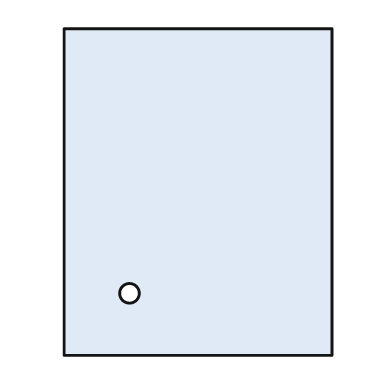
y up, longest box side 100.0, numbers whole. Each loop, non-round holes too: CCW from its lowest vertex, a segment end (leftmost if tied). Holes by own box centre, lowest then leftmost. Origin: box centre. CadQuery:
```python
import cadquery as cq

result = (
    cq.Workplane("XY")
    .moveTo(-41.0, -50.0)
    .lineTo(41.0, -50.0)
    .lineTo(41.0, 50.0)
    .lineTo(-41.0, 50.0)
    .close()
    .moveTo(-21.0, -31.0)
    .circle(3.0)
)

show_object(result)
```